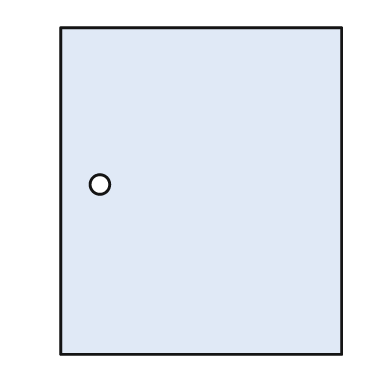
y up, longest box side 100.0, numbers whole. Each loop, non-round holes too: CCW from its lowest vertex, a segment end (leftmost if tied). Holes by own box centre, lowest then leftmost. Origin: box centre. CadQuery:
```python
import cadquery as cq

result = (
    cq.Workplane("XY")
    .moveTo(-43.0, -50.0)
    .lineTo(43.0, -50.0)
    .lineTo(43.0, 50.0)
    .lineTo(-43.0, 50.0)
    .close()
    .moveTo(-31.0, 2.0)
    .circle(3.0)
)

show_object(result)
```